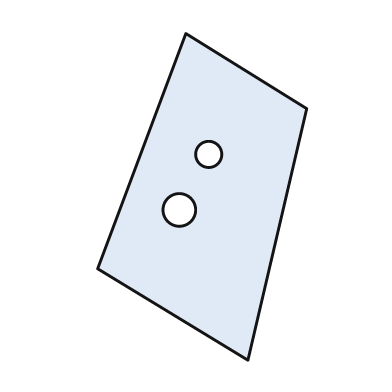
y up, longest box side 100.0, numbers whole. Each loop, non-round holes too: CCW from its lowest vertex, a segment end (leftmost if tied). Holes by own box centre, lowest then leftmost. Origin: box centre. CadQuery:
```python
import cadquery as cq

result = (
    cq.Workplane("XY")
    .moveTo(14.0, -50.0)
    .lineTo(32.0, 27.0)
    .lineTo(-5.0, 50.0)
    .lineTo(-32.0, -22.0)
    .close()
    .moveTo(-7.0, -4.0)
    .circle(5.0)
    .moveTo(2.0, 13.0)
    .circle(4.0)
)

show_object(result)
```